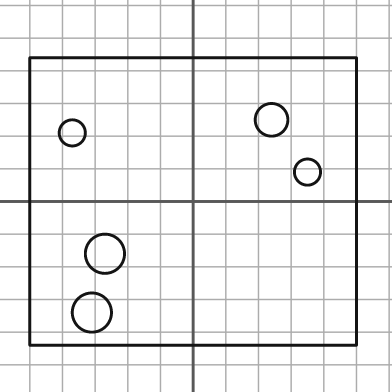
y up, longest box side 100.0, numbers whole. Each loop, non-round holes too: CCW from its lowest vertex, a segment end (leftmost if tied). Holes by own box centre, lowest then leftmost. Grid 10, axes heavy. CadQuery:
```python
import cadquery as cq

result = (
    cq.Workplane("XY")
    .moveTo(-50.0, -44.0)
    .lineTo(50.0, -44.0)
    .lineTo(50.0, 44.0)
    .lineTo(-50.0, 44.0)
    .close()
    .moveTo(-31.0, -34.0)
    .circle(6.0)
    .moveTo(-27.0, -16.0)
    .circle(6.0)
    .moveTo(35.0, 9.0)
    .circle(4.0)
    .moveTo(-37.0, 21.0)
    .circle(4.0)
    .moveTo(24.0, 25.0)
    .circle(5.0)
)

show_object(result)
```